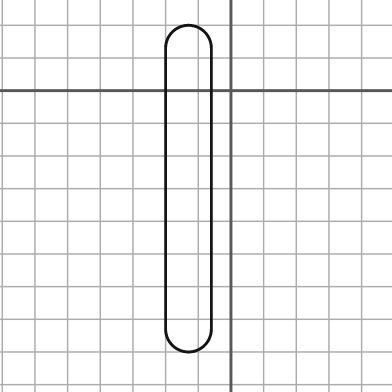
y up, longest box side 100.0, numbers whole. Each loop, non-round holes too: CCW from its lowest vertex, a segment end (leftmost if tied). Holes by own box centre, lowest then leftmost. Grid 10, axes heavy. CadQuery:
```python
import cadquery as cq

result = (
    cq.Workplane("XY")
    .moveTo(-20.0, -73.0)
    .threePointArc((-13.0, -80.0), (-6.0, -73.0))
    .lineTo(-6.0, 13.0)
    .threePointArc((-13.0, 20.0), (-20.0, 13.0))
    .close()
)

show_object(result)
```